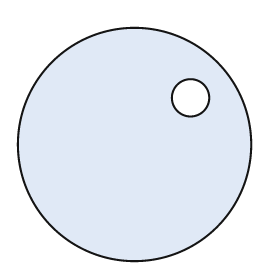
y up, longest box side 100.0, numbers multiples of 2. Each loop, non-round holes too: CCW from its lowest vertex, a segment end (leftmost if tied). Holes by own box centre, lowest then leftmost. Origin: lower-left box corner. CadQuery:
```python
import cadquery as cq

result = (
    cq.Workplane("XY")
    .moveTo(50.0, 50.0)
    .circle(50.0)
    .moveTo(74.0, 70.0)
    .circle(8.0)
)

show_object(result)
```